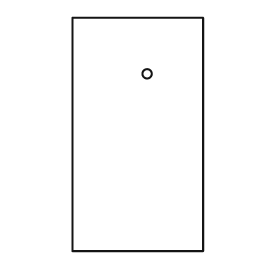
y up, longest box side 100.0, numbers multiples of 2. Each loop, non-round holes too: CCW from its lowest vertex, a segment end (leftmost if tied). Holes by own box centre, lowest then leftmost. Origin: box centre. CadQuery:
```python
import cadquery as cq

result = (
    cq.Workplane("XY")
    .moveTo(-28.0, -50.0)
    .lineTo(28.0, -50.0)
    .lineTo(28.0, 50.0)
    .lineTo(-28.0, 50.0)
    .close()
    .moveTo(4.0, 26.0)
    .circle(2.0)
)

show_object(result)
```